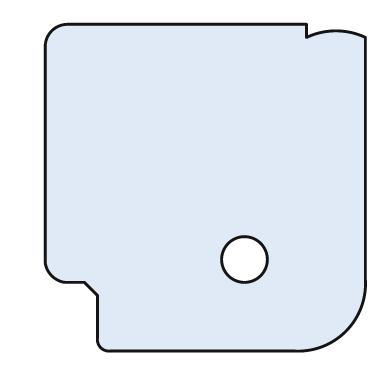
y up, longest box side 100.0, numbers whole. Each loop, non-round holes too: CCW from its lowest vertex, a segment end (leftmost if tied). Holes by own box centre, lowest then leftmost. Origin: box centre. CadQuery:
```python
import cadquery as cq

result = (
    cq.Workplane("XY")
    .moveTo(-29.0, -50.0)
    .lineTo(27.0, -50.0)
    .threePointArc((43.0, -44.0), (49.0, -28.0))
    .lineTo(49.0, 46.0)
    .threePointArc((40.0, 48.0), (31.0, 46.0))
    .lineTo(31.0, 50.0)
    .lineTo(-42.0, 50.0)
    .threePointArc((-47.0, 48.0), (-49.0, 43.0))
    .lineTo(-49.0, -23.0)
    .threePointArc((-47.0, -27.0), (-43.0, -29.0))
    .lineTo(-37.0, -29.0)
    .lineTo(-33.0, -33.0)
    .lineTo(-33.0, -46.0)
    .threePointArc((-32.0, -49.0), (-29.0, -50.0))
    .close()
    .moveTo(12.0, -22.0)
    .circle(7.0)
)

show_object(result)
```